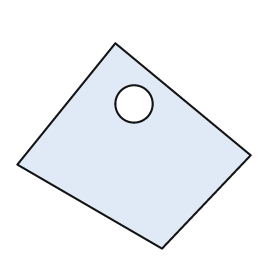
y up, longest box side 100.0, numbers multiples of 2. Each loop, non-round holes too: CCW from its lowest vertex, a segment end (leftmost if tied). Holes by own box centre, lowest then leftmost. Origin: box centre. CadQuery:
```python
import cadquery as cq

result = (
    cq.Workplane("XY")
    .moveTo(12.0, -44.0)
    .lineTo(50.0, -4.0)
    .lineTo(-8.0, 44.0)
    .lineTo(-50.0, -8.0)
    .close()
    .moveTo(0.0, 18.0)
    .circle(8.0)
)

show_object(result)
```